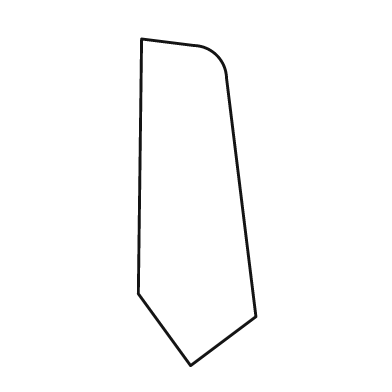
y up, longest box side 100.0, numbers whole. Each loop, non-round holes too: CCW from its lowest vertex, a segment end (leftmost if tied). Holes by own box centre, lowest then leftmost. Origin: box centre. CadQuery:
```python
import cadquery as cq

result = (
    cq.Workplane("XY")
    .moveTo(-2.0, -50.0)
    .lineTo(18.0, -35.0)
    .lineTo(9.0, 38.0)
    .threePointArc((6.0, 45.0), (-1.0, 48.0))
    .lineTo(-17.0, 50.0)
    .lineTo(-18.0, -28.0)
    .close()
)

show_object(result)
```